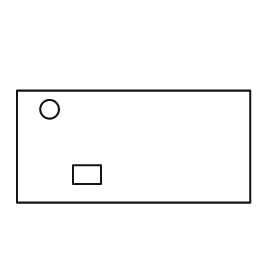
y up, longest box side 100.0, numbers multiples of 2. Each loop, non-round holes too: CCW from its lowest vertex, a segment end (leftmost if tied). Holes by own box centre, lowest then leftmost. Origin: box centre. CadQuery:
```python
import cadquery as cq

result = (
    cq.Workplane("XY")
    .moveTo(-50.0, -24.0)
    .lineTo(50.0, -24.0)
    .lineTo(50.0, 24.0)
    .lineTo(-50.0, 24.0)
    .close()
    .moveTo(-26.0, -16.0)
    .lineTo(-14.0, -16.0)
    .lineTo(-14.0, -8.0)
    .lineTo(-26.0, -8.0)
    .close()
    .moveTo(-36.0, 16.0)
    .circle(4.0)
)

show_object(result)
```